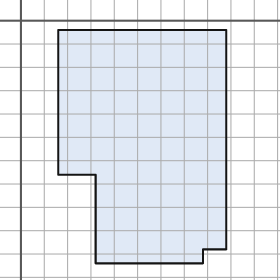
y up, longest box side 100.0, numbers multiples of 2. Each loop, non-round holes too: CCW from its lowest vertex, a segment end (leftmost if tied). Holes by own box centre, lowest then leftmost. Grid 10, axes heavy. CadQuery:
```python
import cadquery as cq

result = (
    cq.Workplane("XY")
    .moveTo(32.0, -104.0)
    .lineTo(78.0, -104.0)
    .lineTo(78.0, -98.0)
    .lineTo(88.0, -98.0)
    .lineTo(88.0, -4.0)
    .lineTo(16.0, -4.0)
    .lineTo(16.0, -66.0)
    .lineTo(32.0, -66.0)
    .close()
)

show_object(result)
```